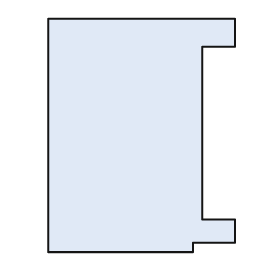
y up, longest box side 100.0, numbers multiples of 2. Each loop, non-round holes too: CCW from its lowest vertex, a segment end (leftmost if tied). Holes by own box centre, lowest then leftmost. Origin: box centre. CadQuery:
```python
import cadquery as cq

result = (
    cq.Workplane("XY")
    .moveTo(-40.0, -50.0)
    .lineTo(22.0, -50.0)
    .lineTo(22.0, -46.0)
    .lineTo(40.0, -46.0)
    .lineTo(40.0, -36.0)
    .lineTo(26.0, -36.0)
    .lineTo(26.0, 38.0)
    .lineTo(40.0, 38.0)
    .lineTo(40.0, 50.0)
    .lineTo(-40.0, 50.0)
    .close()
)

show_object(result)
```